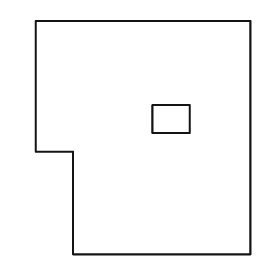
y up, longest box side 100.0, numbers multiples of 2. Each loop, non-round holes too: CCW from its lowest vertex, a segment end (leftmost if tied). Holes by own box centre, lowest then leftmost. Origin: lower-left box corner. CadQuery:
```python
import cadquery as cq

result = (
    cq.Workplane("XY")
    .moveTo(16.0, 0.0)
    .lineTo(92.0, 0.0)
    .lineTo(92.0, 100.0)
    .lineTo(0.0, 100.0)
    .lineTo(0.0, 44.0)
    .lineTo(16.0, 44.0)
    .close()
    .moveTo(50.0, 52.0)
    .lineTo(66.0, 52.0)
    .lineTo(66.0, 64.0)
    .lineTo(50.0, 64.0)
    .close()
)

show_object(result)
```